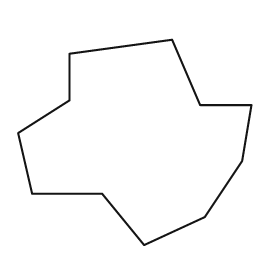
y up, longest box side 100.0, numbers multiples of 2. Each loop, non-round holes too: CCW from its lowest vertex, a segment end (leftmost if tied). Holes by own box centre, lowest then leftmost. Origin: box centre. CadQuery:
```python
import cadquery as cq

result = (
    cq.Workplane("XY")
    .moveTo(4.0, -44.0)
    .lineTo(30.0, -32.0)
    .lineTo(46.0, -8.0)
    .lineTo(50.0, 16.0)
    .lineTo(28.0, 16.0)
    .lineTo(16.0, 44.0)
    .lineTo(-28.0, 38.0)
    .lineTo(-28.0, 18.0)
    .lineTo(-50.0, 4.0)
    .lineTo(-44.0, -22.0)
    .lineTo(-14.0, -22.0)
    .close()
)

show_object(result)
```